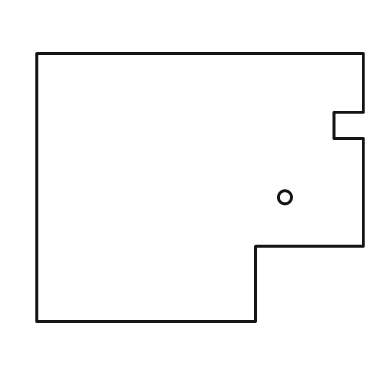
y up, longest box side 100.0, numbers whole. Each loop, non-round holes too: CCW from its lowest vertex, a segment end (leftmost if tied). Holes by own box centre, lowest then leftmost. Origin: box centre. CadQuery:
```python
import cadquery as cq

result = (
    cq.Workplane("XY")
    .moveTo(-50.0, -41.0)
    .lineTo(17.0, -41.0)
    .lineTo(17.0, -18.0)
    .lineTo(50.0, -18.0)
    .lineTo(50.0, 15.0)
    .lineTo(41.0, 15.0)
    .lineTo(41.0, 23.0)
    .lineTo(50.0, 23.0)
    .lineTo(50.0, 41.0)
    .lineTo(-50.0, 41.0)
    .close()
    .moveTo(26.0, -3.0)
    .circle(2.0)
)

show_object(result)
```